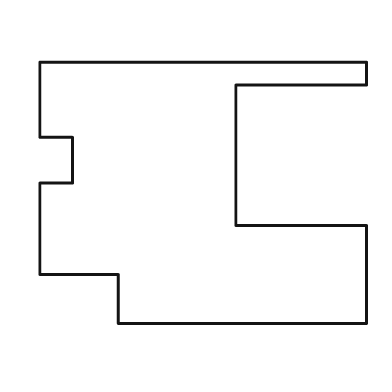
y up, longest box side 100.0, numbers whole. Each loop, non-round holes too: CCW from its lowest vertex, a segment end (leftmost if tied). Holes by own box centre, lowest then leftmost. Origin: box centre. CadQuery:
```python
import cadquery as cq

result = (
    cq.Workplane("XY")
    .moveTo(-26.0, -40.0)
    .lineTo(50.0, -40.0)
    .lineTo(50.0, -10.0)
    .lineTo(10.0, -10.0)
    .lineTo(10.0, 33.0)
    .lineTo(50.0, 33.0)
    .lineTo(50.0, 40.0)
    .lineTo(-50.0, 40.0)
    .lineTo(-50.0, 17.0)
    .lineTo(-40.0, 17.0)
    .lineTo(-40.0, 3.0)
    .lineTo(-50.0, 3.0)
    .lineTo(-50.0, -25.0)
    .lineTo(-26.0, -25.0)
    .close()
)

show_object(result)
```